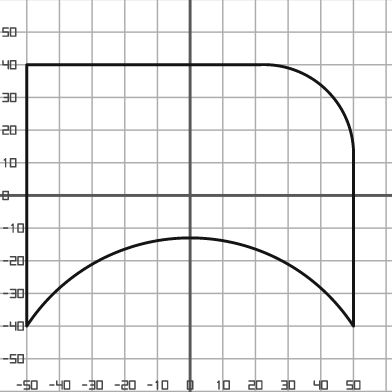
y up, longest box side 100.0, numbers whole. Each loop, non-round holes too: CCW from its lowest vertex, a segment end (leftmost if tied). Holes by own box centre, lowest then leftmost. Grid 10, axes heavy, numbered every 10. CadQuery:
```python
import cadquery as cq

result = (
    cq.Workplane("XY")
    .moveTo(-50.0, -40.0)
    .threePointArc((0.0, -13.0), (50.0, -40.0))
    .lineTo(50.0, 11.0)
    .threePointArc((42.0, 32.0), (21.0, 40.0))
    .lineTo(-50.0, 40.0)
    .close()
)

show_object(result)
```